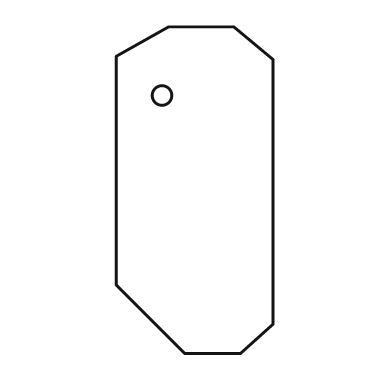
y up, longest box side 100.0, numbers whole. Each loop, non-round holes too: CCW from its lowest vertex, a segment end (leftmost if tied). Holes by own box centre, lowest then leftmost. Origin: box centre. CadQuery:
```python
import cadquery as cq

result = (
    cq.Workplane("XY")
    .moveTo(-3.0, -50.0)
    .lineTo(14.0, -50.0)
    .lineTo(24.0, -41.0)
    .lineTo(24.0, 40.0)
    .lineTo(12.0, 50.0)
    .lineTo(-8.0, 50.0)
    .lineTo(-24.0, 41.0)
    .lineTo(-24.0, -29.0)
    .close()
    .moveTo(-10.0, 29.0)
    .circle(3.0)
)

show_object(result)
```